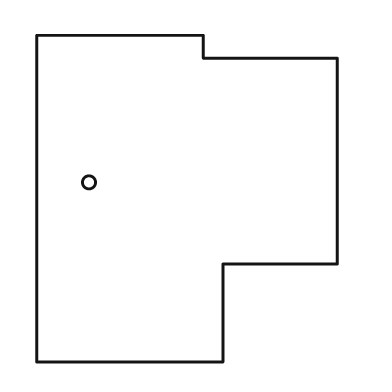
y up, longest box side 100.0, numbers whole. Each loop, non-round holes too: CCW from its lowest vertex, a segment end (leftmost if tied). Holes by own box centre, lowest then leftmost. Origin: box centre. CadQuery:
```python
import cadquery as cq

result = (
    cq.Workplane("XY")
    .moveTo(-46.0, -50.0)
    .lineTo(11.0, -50.0)
    .lineTo(11.0, -20.0)
    .lineTo(46.0, -20.0)
    .lineTo(46.0, 43.0)
    .lineTo(5.0, 43.0)
    .lineTo(5.0, 50.0)
    .lineTo(-46.0, 50.0)
    .close()
    .moveTo(-30.0, 5.0)
    .circle(2.0)
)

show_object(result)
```